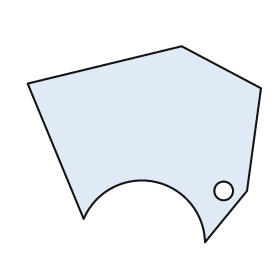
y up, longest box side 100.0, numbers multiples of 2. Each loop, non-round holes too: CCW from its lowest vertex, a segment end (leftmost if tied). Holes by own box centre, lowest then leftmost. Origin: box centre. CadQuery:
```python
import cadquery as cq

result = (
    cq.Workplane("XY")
    .moveTo(26.0, -42.0)
    .lineTo(44.0, -20.0)
    .lineTo(50.0, 24.0)
    .lineTo(16.0, 42.0)
    .lineTo(-50.0, 26.0)
    .lineTo(-26.0, -32.0)
    .threePointArc((4.0, -16.0), (26.0, -42.0))
    .close()
    .moveTo(34.0, -20.0)
    .circle(4.0)
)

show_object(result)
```